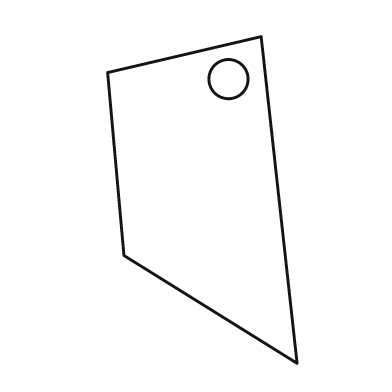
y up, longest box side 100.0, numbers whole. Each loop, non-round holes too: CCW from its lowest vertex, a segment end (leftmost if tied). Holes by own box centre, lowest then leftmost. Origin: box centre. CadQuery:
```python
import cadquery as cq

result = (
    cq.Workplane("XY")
    .moveTo(29.0, -50.0)
    .lineTo(18.0, 50.0)
    .lineTo(-29.0, 39.0)
    .lineTo(-24.0, -17.0)
    .close()
    .moveTo(8.0, 37.0)
    .circle(6.0)
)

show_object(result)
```